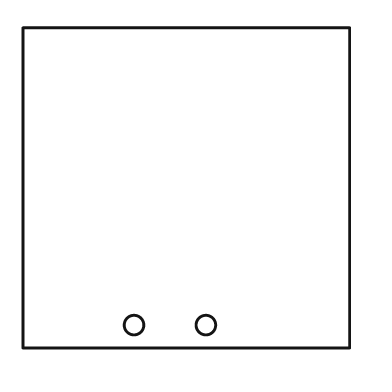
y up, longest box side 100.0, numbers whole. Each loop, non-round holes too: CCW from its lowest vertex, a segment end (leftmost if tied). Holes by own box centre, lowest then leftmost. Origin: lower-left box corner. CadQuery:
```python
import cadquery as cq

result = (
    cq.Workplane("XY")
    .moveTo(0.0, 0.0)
    .lineTo(100.0, 0.0)
    .lineTo(100.0, 98.0)
    .lineTo(0.0, 98.0)
    .close()
    .moveTo(34.0, 7.0)
    .circle(3.0)
    .moveTo(56.0, 7.0)
    .circle(3.0)
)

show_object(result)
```